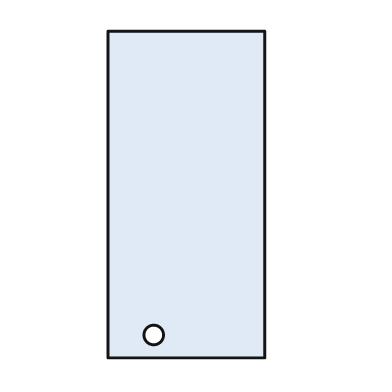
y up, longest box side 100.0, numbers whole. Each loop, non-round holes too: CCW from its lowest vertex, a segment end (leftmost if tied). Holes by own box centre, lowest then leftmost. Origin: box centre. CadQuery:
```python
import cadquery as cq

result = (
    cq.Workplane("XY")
    .moveTo(-24.0, -50.0)
    .lineTo(24.0, -50.0)
    .lineTo(24.0, 50.0)
    .lineTo(-24.0, 50.0)
    .close()
    .moveTo(-10.0, -43.0)
    .circle(3.0)
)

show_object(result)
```